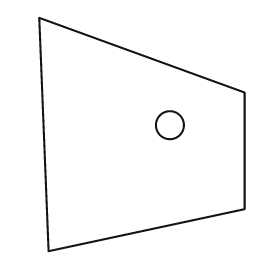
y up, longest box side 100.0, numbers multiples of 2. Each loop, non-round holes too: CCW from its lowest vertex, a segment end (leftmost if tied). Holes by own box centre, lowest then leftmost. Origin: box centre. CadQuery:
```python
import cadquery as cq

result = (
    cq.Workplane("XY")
    .moveTo(-40.0, -50.0)
    .lineTo(44.0, -32.0)
    .lineTo(44.0, 18.0)
    .lineTo(-44.0, 50.0)
    .close()
    .moveTo(12.0, 4.0)
    .circle(6.0)
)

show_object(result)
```